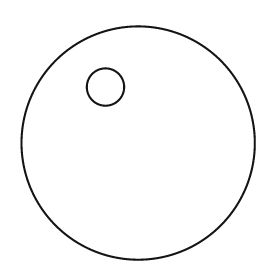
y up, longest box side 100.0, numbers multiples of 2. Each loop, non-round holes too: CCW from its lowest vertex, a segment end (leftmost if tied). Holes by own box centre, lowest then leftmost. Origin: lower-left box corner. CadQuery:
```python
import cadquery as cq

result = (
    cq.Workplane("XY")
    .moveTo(50.0, 50.0)
    .circle(50.0)
    .moveTo(36.0, 74.0)
    .circle(8.0)
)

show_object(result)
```